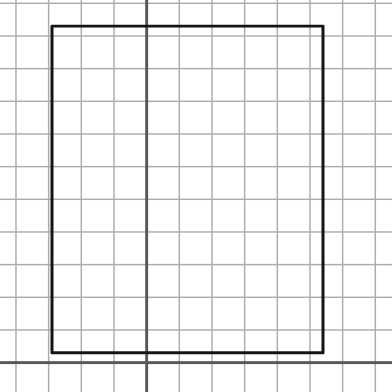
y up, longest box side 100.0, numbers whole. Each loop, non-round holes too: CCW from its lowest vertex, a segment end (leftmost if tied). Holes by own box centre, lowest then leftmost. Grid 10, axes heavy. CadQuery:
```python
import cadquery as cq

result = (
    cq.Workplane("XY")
    .moveTo(-29.0, 3.0)
    .lineTo(54.0, 3.0)
    .lineTo(54.0, 103.0)
    .lineTo(-29.0, 103.0)
    .close()
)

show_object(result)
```